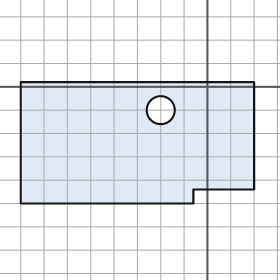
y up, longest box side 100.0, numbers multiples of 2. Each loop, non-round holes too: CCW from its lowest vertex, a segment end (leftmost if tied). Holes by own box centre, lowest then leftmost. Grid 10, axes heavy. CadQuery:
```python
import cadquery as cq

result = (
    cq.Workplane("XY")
    .moveTo(-80.0, -50.0)
    .lineTo(-6.0, -50.0)
    .lineTo(-6.0, -44.0)
    .lineTo(20.0, -44.0)
    .lineTo(20.0, 2.0)
    .lineTo(-80.0, 2.0)
    .close()
    .moveTo(-20.0, -10.0)
    .circle(6.0)
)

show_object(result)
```